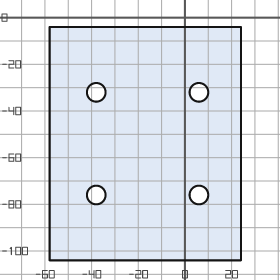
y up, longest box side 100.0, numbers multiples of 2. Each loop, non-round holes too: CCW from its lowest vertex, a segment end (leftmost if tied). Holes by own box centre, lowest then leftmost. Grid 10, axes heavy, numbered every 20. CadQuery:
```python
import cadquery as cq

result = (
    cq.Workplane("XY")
    .moveTo(-58.0, -104.0)
    .lineTo(24.0, -104.0)
    .lineTo(24.0, -4.0)
    .lineTo(-58.0, -4.0)
    .close()
    .moveTo(-38.0, -76.0)
    .circle(4.0)
    .moveTo(6.0, -76.0)
    .circle(4.0)
    .moveTo(-38.0, -32.0)
    .circle(4.0)
    .moveTo(6.0, -32.0)
    .circle(4.0)
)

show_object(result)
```